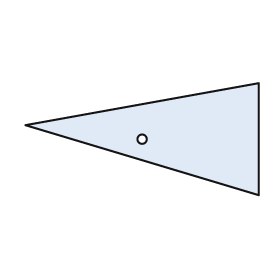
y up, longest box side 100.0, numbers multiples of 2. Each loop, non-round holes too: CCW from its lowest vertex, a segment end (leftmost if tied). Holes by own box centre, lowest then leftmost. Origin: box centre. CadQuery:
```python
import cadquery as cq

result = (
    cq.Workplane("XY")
    .moveTo(50.0, -24.0)
    .lineTo(50.0, 24.0)
    .lineTo(-50.0, 6.0)
    .close()
    .moveTo(0.0, 0.0)
    .circle(2.0)
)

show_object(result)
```